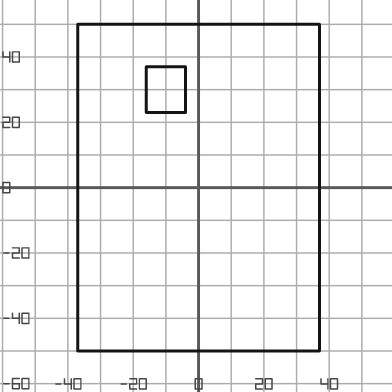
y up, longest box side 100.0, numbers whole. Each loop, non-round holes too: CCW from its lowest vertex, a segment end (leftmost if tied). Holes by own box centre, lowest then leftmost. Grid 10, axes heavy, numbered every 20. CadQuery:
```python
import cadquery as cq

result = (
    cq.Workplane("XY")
    .moveTo(-37.0, -50.0)
    .lineTo(37.0, -50.0)
    .lineTo(37.0, 50.0)
    .lineTo(-37.0, 50.0)
    .close()
    .moveTo(-16.0, 23.0)
    .lineTo(-4.0, 23.0)
    .lineTo(-4.0, 37.0)
    .lineTo(-16.0, 37.0)
    .close()
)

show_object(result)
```